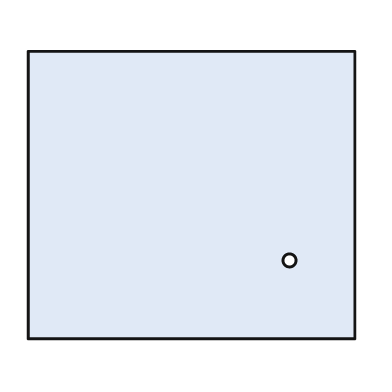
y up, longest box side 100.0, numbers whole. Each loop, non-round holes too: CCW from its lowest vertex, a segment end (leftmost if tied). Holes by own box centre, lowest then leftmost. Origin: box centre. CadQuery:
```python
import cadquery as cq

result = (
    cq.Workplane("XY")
    .moveTo(-50.0, -44.0)
    .lineTo(50.0, -44.0)
    .lineTo(50.0, 44.0)
    .lineTo(-50.0, 44.0)
    .close()
    .moveTo(30.0, -20.0)
    .circle(2.0)
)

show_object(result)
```